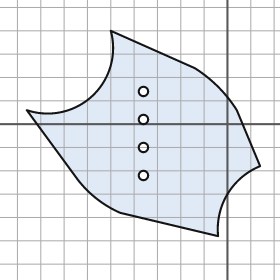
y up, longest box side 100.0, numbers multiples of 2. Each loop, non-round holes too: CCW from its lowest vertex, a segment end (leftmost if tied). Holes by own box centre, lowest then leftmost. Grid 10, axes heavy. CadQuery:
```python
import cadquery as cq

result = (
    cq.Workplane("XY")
    .moveTo(-4.0, -48.0)
    .threePointArc((0.0, -30.0), (14.0, -18.0))
    .lineTo(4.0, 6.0)
    .threePointArc((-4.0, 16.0), (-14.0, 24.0))
    .lineTo(-50.0, 40.0)
    .threePointArc((-58.0, 12.0), (-86.0, 6.0))
    .lineTo(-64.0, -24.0)
    .threePointArc((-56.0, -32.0), (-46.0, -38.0))
    .close()
    .moveTo(-36.0, -22.0)
    .circle(2.0)
    .moveTo(-36.0, -10.0)
    .circle(2.0)
    .moveTo(-36.0, 2.0)
    .circle(2.0)
    .moveTo(-36.0, 14.0)
    .circle(2.0)
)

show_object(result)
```